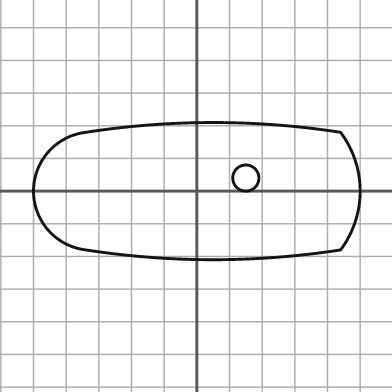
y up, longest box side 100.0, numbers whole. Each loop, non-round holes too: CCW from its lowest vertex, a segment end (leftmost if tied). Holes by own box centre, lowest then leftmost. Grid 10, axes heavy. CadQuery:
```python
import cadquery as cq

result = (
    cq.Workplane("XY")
    .moveTo(-34.0, -18.0)
    .threePointArc((5.0, -21.0), (44.0, -18.0))
    .threePointArc((50.0, 0.0), (44.0, 18.0))
    .threePointArc((5.0, 21.0), (-34.0, 18.0))
    .threePointArc((-50.0, 0.0), (-34.0, -18.0))
    .close()
    .moveTo(15.0, 4.0)
    .circle(4.0)
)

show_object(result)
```